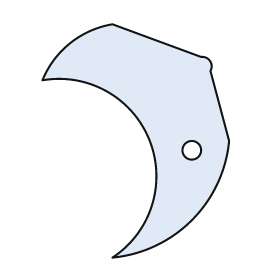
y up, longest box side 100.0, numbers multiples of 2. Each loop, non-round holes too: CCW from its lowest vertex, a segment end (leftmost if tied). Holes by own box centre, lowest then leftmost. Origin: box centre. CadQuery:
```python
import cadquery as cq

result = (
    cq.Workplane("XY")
    .moveTo(-10.0, -50.0)
    .threePointArc((24.0, -34.0), (40.0, 0.0))
    .lineTo(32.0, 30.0)
    .threePointArc((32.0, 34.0), (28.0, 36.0))
    .lineTo(-10.0, 50.0)
    .threePointArc((-28.0, 42.0), (-40.0, 26.0))
    .threePointArc((6.0, 0.0), (-10.0, -50.0))
    .close()
    .moveTo(24.0, -4.0)
    .circle(4.0)
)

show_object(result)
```